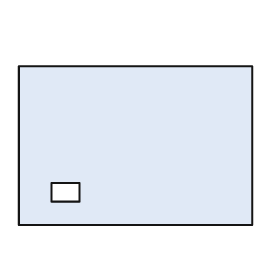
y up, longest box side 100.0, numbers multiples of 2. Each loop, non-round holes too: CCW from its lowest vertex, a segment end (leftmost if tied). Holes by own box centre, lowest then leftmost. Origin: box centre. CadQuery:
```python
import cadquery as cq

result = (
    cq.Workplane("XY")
    .moveTo(-50.0, -34.0)
    .lineTo(50.0, -34.0)
    .lineTo(50.0, 34.0)
    .lineTo(-50.0, 34.0)
    .close()
    .moveTo(-36.0, -24.0)
    .lineTo(-24.0, -24.0)
    .lineTo(-24.0, -16.0)
    .lineTo(-36.0, -16.0)
    .close()
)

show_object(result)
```